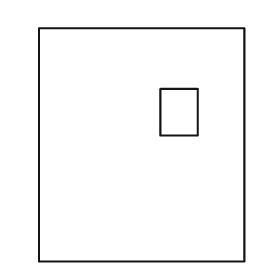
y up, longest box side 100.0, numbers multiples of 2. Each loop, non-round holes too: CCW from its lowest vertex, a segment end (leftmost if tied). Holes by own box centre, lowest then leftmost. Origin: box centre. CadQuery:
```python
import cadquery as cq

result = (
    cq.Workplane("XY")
    .moveTo(-44.0, -50.0)
    .lineTo(44.0, -50.0)
    .lineTo(44.0, 50.0)
    .lineTo(-44.0, 50.0)
    .close()
    .moveTo(8.0, 4.0)
    .lineTo(24.0, 4.0)
    .lineTo(24.0, 24.0)
    .lineTo(8.0, 24.0)
    .close()
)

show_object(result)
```